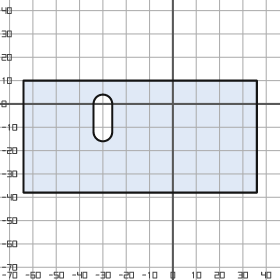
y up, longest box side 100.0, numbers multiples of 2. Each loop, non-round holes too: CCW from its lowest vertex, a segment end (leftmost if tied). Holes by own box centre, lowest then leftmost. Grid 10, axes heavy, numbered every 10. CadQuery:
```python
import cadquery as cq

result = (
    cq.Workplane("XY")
    .moveTo(-64.0, -38.0)
    .lineTo(36.0, -38.0)
    .lineTo(36.0, 10.0)
    .lineTo(-64.0, 10.0)
    .close()
    .moveTo(-34.0, -12.0)
    .threePointArc((-30.0, -16.0), (-26.0, -12.0))
    .lineTo(-26.0, 0.0)
    .threePointArc((-30.0, 4.0), (-34.0, 0.0))
    .close()
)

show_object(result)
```